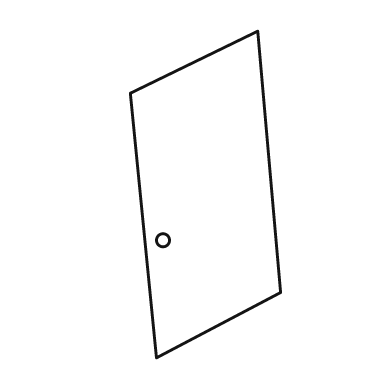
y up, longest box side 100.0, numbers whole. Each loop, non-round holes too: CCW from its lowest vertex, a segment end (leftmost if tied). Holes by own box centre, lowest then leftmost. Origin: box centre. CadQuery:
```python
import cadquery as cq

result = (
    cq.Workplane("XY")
    .moveTo(-15.0, -50.0)
    .lineTo(23.0, -30.0)
    .lineTo(16.0, 50.0)
    .lineTo(-23.0, 31.0)
    .close()
    .moveTo(-13.0, -14.0)
    .circle(2.0)
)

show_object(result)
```